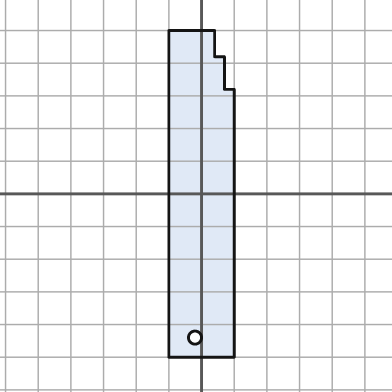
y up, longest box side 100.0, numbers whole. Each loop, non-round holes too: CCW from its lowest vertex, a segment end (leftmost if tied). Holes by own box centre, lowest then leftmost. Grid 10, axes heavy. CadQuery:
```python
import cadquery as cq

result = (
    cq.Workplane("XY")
    .moveTo(-10.0, -50.0)
    .lineTo(10.0, -50.0)
    .lineTo(10.0, 32.0)
    .lineTo(7.0, 32.0)
    .lineTo(7.0, 42.0)
    .lineTo(4.0, 42.0)
    .lineTo(4.0, 50.0)
    .lineTo(-10.0, 50.0)
    .close()
    .moveTo(-2.0, -44.0)
    .circle(2.0)
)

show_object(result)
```